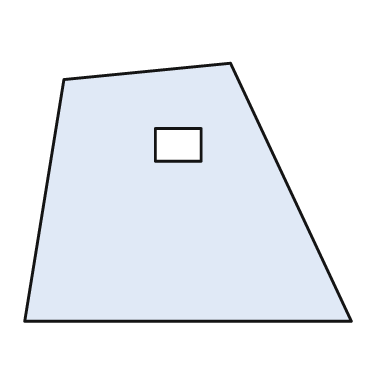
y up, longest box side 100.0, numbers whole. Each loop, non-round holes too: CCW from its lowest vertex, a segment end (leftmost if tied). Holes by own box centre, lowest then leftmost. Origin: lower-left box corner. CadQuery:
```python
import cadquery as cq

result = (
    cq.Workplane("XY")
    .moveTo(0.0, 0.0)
    .lineTo(100.0, 0.0)
    .lineTo(63.0, 79.0)
    .lineTo(12.0, 74.0)
    .close()
    .moveTo(40.0, 49.0)
    .lineTo(54.0, 49.0)
    .lineTo(54.0, 59.0)
    .lineTo(40.0, 59.0)
    .close()
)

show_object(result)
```